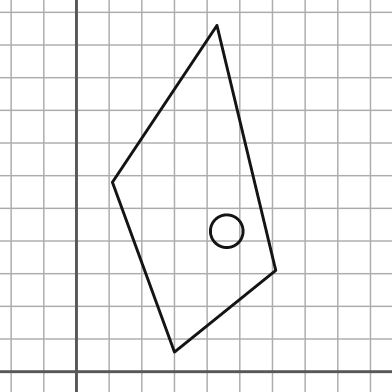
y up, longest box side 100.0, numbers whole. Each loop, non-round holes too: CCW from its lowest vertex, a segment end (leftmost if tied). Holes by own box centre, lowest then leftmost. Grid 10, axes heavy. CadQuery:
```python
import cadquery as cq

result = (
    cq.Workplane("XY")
    .moveTo(30.0, 6.0)
    .lineTo(61.0, 31.0)
    .lineTo(43.0, 106.0)
    .lineTo(11.0, 58.0)
    .close()
    .moveTo(46.0, 43.0)
    .circle(5.0)
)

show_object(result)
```